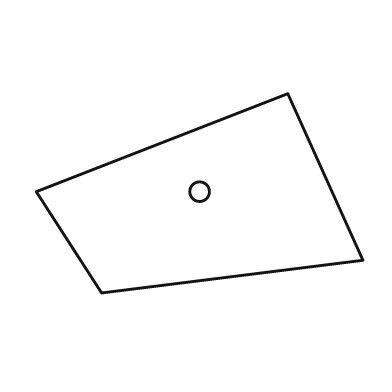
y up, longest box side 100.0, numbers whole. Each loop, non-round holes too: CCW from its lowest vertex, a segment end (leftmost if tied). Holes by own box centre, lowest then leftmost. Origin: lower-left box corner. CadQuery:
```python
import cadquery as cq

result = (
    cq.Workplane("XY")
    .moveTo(20.0, 0.0)
    .lineTo(100.0, 10.0)
    .lineTo(77.0, 61.0)
    .lineTo(0.0, 31.0)
    .close()
    .moveTo(50.0, 31.0)
    .circle(3.0)
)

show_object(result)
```